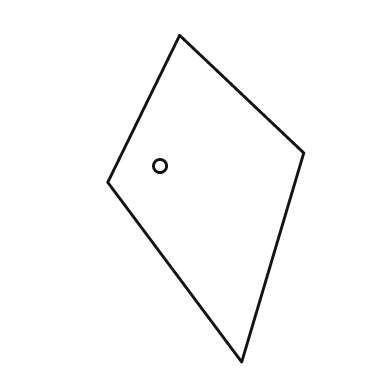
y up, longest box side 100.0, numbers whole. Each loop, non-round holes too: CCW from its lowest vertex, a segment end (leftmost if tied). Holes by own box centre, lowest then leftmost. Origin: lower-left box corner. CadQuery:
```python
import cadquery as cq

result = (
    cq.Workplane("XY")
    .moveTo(41.0, 0.0)
    .lineTo(60.0, 64.0)
    .lineTo(22.0, 100.0)
    .lineTo(0.0, 55.0)
    .close()
    .moveTo(16.0, 60.0)
    .circle(2.0)
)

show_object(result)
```